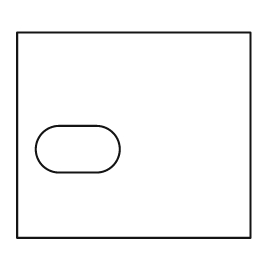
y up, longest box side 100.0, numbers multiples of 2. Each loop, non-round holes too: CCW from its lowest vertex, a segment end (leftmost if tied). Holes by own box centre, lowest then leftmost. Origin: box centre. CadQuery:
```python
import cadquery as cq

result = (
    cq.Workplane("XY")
    .moveTo(-50.0, -44.0)
    .lineTo(50.0, -44.0)
    .lineTo(50.0, 44.0)
    .lineTo(-50.0, 44.0)
    .close()
    .moveTo(-32.0, -16.0)
    .lineTo(-16.0, -16.0)
    .threePointArc((-6.0, -6.0), (-16.0, 4.0))
    .lineTo(-32.0, 4.0)
    .threePointArc((-42.0, -6.0), (-32.0, -16.0))
    .close()
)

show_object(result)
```